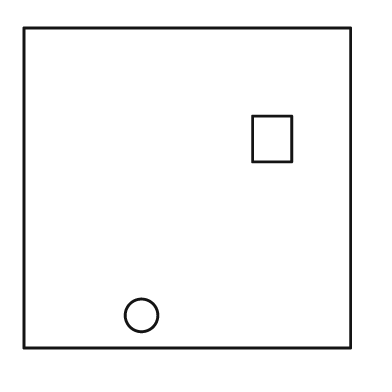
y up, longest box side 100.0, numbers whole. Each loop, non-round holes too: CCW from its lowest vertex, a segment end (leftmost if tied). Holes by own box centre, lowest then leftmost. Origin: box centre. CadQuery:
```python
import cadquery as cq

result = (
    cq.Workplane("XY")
    .moveTo(-50.0, -49.0)
    .lineTo(50.0, -49.0)
    .lineTo(50.0, 49.0)
    .lineTo(-50.0, 49.0)
    .close()
    .moveTo(-14.0, -39.0)
    .circle(5.0)
    .moveTo(20.0, 8.0)
    .lineTo(32.0, 8.0)
    .lineTo(32.0, 22.0)
    .lineTo(20.0, 22.0)
    .close()
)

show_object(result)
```